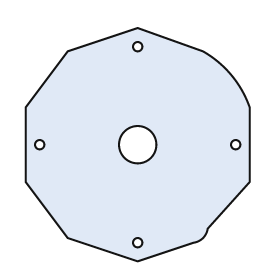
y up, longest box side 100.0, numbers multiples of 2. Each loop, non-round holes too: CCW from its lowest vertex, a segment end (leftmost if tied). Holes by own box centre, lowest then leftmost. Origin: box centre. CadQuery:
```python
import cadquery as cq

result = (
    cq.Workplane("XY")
    .moveTo(0.0, -50.0)
    .lineTo(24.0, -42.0)
    .threePointArc((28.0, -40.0), (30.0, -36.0))
    .lineTo(48.0, -16.0)
    .lineTo(48.0, 16.0)
    .threePointArc((40.0, 30.0), (28.0, 40.0))
    .lineTo(0.0, 50.0)
    .lineTo(-30.0, 40.0)
    .lineTo(-48.0, 16.0)
    .lineTo(-48.0, -16.0)
    .lineTo(-30.0, -40.0)
    .close()
    .moveTo(0.0, -42.0)
    .circle(2.0)
    .moveTo(-42.0, 0.0)
    .circle(2.0)
    .moveTo(0.0, 0.0)
    .circle(8.0)
    .moveTo(42.0, 0.0)
    .circle(2.0)
    .moveTo(0.0, 42.0)
    .circle(2.0)
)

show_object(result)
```